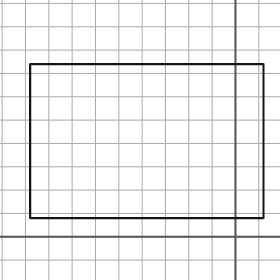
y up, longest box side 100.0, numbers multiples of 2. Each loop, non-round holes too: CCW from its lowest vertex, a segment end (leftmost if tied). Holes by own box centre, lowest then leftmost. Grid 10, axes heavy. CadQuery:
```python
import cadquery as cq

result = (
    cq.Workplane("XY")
    .moveTo(-88.0, 8.0)
    .lineTo(12.0, 8.0)
    .lineTo(12.0, 74.0)
    .lineTo(-88.0, 74.0)
    .close()
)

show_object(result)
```